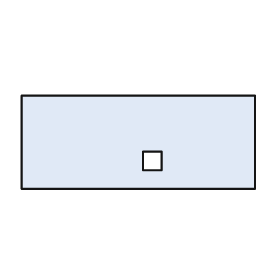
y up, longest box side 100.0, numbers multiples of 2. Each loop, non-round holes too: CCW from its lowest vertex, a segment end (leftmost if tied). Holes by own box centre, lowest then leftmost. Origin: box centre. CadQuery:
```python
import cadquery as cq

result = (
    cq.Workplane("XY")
    .moveTo(-50.0, -20.0)
    .lineTo(50.0, -20.0)
    .lineTo(50.0, 20.0)
    .lineTo(-50.0, 20.0)
    .close()
    .moveTo(2.0, -12.0)
    .lineTo(10.0, -12.0)
    .lineTo(10.0, -4.0)
    .lineTo(2.0, -4.0)
    .close()
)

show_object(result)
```